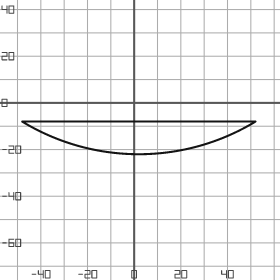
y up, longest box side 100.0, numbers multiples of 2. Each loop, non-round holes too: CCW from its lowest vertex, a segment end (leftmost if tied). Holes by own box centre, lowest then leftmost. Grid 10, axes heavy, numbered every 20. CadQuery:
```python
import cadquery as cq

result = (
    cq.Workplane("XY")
    .moveTo(-48.0, -8.0)
    .threePointArc((2.0, -22.0), (52.0, -8.0))
    .close()
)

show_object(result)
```